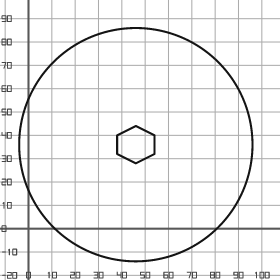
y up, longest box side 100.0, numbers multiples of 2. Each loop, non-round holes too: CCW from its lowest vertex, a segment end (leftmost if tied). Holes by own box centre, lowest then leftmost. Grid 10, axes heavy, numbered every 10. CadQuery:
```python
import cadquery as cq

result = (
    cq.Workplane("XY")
    .moveTo(46.0, 36.0)
    .circle(50.0)
    .moveTo(46.0, 28.0)
    .lineTo(54.0, 32.0)
    .lineTo(54.0, 40.0)
    .lineTo(46.0, 44.0)
    .lineTo(38.0, 40.0)
    .lineTo(38.0, 32.0)
    .close()
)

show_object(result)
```